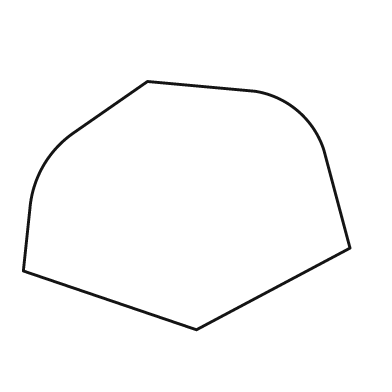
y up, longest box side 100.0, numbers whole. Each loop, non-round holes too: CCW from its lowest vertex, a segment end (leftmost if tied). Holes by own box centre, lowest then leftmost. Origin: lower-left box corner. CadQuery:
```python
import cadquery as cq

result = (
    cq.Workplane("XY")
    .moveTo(53.0, 0.0)
    .lineTo(100.0, 25.0)
    .lineTo(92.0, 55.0)
    .threePointArc((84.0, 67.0), (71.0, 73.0))
    .lineTo(38.0, 76.0)
    .lineTo(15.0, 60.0)
    .threePointArc((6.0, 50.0), (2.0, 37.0))
    .lineTo(0.0, 18.0)
    .close()
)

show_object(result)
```